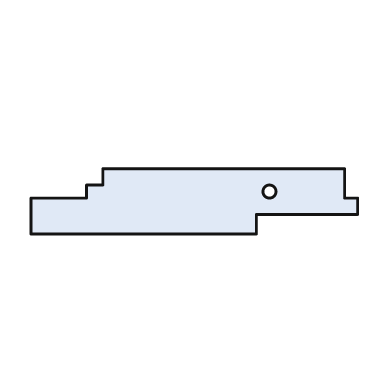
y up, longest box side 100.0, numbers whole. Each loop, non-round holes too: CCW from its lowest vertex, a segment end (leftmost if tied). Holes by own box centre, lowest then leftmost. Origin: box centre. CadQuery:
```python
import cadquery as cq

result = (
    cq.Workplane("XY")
    .moveTo(-50.0, -10.0)
    .lineTo(19.0, -10.0)
    .lineTo(19.0, -4.0)
    .lineTo(50.0, -4.0)
    .lineTo(50.0, 1.0)
    .lineTo(46.0, 1.0)
    .lineTo(46.0, 10.0)
    .lineTo(-28.0, 10.0)
    .lineTo(-28.0, 5.0)
    .lineTo(-33.0, 5.0)
    .lineTo(-33.0, 1.0)
    .lineTo(-50.0, 1.0)
    .close()
    .moveTo(23.0, 3.0)
    .circle(2.0)
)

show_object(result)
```